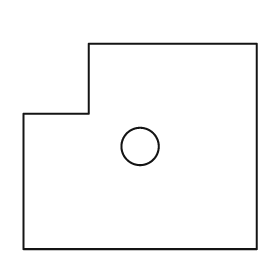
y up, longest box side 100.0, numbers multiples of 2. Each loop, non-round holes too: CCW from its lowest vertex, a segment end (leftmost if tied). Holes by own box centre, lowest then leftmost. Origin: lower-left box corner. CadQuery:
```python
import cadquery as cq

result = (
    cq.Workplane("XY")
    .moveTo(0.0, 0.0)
    .lineTo(100.0, 0.0)
    .lineTo(100.0, 88.0)
    .lineTo(28.0, 88.0)
    .lineTo(28.0, 58.0)
    .lineTo(0.0, 58.0)
    .close()
    .moveTo(50.0, 44.0)
    .circle(8.0)
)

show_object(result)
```